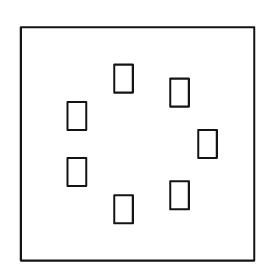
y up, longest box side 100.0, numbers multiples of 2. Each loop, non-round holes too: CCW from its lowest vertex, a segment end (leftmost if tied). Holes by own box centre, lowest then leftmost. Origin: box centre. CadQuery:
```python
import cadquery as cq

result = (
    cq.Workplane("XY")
    .moveTo(-50.0, -50.0)
    .lineTo(50.0, -50.0)
    .lineTo(50.0, 50.0)
    .lineTo(-50.0, 50.0)
    .close()
    .moveTo(-10.0, -34.0)
    .lineTo(-2.0, -34.0)
    .lineTo(-2.0, -22.0)
    .lineTo(-10.0, -22.0)
    .close()
    .moveTo(14.0, -28.0)
    .lineTo(22.0, -28.0)
    .lineTo(22.0, -16.0)
    .lineTo(14.0, -16.0)
    .close()
    .moveTo(-30.0, -18.0)
    .lineTo(-22.0, -18.0)
    .lineTo(-22.0, -6.0)
    .lineTo(-30.0, -6.0)
    .close()
    .moveTo(26.0, -6.0)
    .lineTo(34.0, -6.0)
    .lineTo(34.0, 6.0)
    .lineTo(26.0, 6.0)
    .close()
    .moveTo(-30.0, 6.0)
    .lineTo(-22.0, 6.0)
    .lineTo(-22.0, 18.0)
    .lineTo(-30.0, 18.0)
    .close()
    .moveTo(14.0, 16.0)
    .lineTo(22.0, 16.0)
    .lineTo(22.0, 28.0)
    .lineTo(14.0, 28.0)
    .close()
    .moveTo(-10.0, 22.0)
    .lineTo(-2.0, 22.0)
    .lineTo(-2.0, 34.0)
    .lineTo(-10.0, 34.0)
    .close()
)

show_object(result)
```